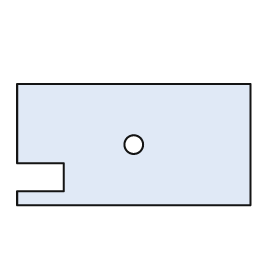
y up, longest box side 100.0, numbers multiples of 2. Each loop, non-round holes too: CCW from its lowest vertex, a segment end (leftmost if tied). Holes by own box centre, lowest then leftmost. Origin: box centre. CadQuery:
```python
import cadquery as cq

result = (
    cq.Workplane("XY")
    .moveTo(-50.0, -26.0)
    .lineTo(50.0, -26.0)
    .lineTo(50.0, 26.0)
    .lineTo(-50.0, 26.0)
    .lineTo(-50.0, -8.0)
    .lineTo(-30.0, -8.0)
    .lineTo(-30.0, -20.0)
    .lineTo(-50.0, -20.0)
    .close()
    .moveTo(0.0, 0.0)
    .circle(4.0)
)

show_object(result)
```